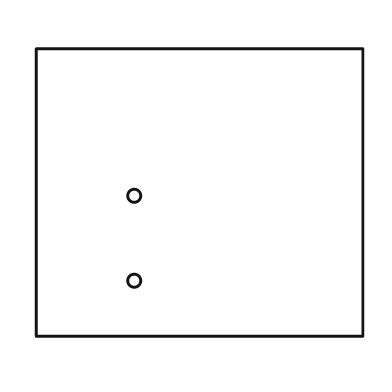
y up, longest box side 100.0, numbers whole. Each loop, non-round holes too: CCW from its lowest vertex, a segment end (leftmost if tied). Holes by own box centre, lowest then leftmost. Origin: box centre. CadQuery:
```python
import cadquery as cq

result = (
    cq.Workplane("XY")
    .moveTo(-50.0, -44.0)
    .lineTo(50.0, -44.0)
    .lineTo(50.0, 44.0)
    .lineTo(-50.0, 44.0)
    .close()
    .moveTo(-20.0, -27.0)
    .circle(2.0)
    .moveTo(-20.0, -1.0)
    .circle(2.0)
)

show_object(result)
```